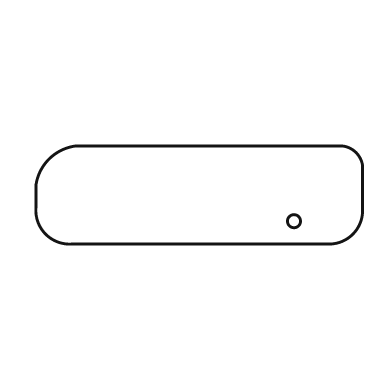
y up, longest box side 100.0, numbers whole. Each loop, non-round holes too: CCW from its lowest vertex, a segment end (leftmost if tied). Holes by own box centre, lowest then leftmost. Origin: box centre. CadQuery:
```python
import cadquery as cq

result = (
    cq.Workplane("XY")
    .moveTo(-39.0, -15.0)
    .lineTo(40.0, -15.0)
    .threePointArc((47.0, -12.0), (50.0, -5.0))
    .lineTo(50.0, 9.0)
    .threePointArc((48.0, 13.0), (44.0, 15.0))
    .lineTo(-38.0, 15.0)
    .threePointArc((-46.0, 11.0), (-50.0, 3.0))
    .lineTo(-50.0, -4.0)
    .threePointArc((-47.0, -12.0), (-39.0, -15.0))
    .close()
    .moveTo(29.0, -8.0)
    .circle(2.0)
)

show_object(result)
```